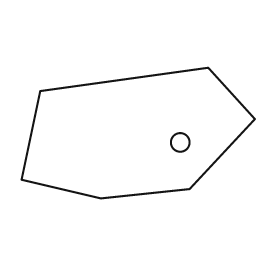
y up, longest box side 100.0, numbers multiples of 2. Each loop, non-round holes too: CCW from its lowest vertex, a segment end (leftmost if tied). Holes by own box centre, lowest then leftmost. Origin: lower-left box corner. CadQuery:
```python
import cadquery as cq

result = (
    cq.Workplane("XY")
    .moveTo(34.0, 0.0)
    .lineTo(72.0, 4.0)
    .lineTo(100.0, 34.0)
    .lineTo(80.0, 56.0)
    .lineTo(8.0, 46.0)
    .lineTo(0.0, 8.0)
    .close()
    .moveTo(68.0, 24.0)
    .circle(4.0)
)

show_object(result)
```